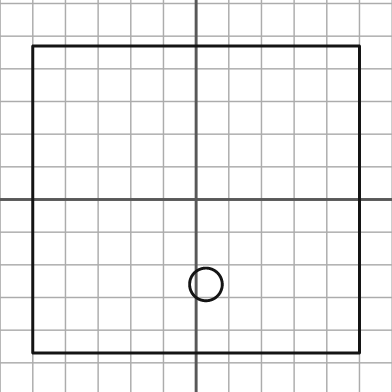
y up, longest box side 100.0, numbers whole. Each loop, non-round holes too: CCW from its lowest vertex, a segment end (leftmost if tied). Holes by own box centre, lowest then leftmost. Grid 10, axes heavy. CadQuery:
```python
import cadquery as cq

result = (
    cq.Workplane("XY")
    .moveTo(-50.0, -47.0)
    .lineTo(50.0, -47.0)
    .lineTo(50.0, 47.0)
    .lineTo(-50.0, 47.0)
    .close()
    .moveTo(3.0, -26.0)
    .circle(5.0)
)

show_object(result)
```